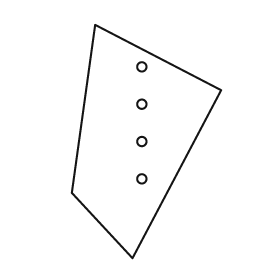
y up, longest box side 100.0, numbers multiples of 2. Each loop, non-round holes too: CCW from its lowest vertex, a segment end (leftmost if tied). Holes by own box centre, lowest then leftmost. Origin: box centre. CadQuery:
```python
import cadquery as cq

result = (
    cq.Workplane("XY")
    .moveTo(-6.0, -50.0)
    .lineTo(32.0, 22.0)
    .lineTo(-22.0, 50.0)
    .lineTo(-32.0, -22.0)
    .close()
    .moveTo(-2.0, -16.0)
    .circle(2.0)
    .moveTo(-2.0, 0.0)
    .circle(2.0)
    .moveTo(-2.0, 16.0)
    .circle(2.0)
    .moveTo(-2.0, 32.0)
    .circle(2.0)
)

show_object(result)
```